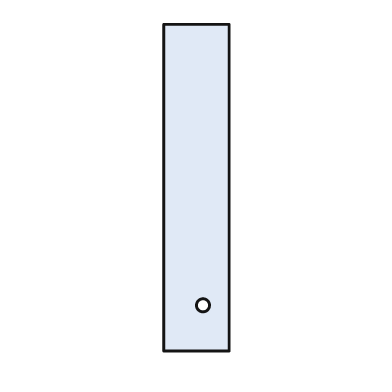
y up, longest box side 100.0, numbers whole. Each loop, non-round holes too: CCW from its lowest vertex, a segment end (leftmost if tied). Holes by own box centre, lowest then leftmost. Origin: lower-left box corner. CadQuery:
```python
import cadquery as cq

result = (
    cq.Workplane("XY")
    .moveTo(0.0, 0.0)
    .lineTo(20.0, 0.0)
    .lineTo(20.0, 100.0)
    .lineTo(0.0, 100.0)
    .close()
    .moveTo(12.0, 14.0)
    .circle(2.0)
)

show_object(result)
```